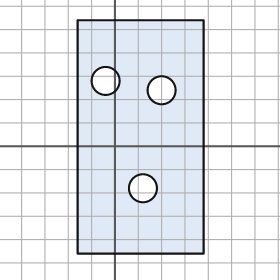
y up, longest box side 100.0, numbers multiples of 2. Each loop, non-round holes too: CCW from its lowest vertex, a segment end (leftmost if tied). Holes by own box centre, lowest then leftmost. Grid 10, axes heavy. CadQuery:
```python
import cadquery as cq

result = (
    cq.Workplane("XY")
    .moveTo(-16.0, -46.0)
    .lineTo(38.0, -46.0)
    .lineTo(38.0, 54.0)
    .lineTo(-16.0, 54.0)
    .close()
    .moveTo(12.0, -18.0)
    .circle(6.0)
    .moveTo(20.0, 24.0)
    .circle(6.0)
    .moveTo(-4.0, 28.0)
    .circle(6.0)
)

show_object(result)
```